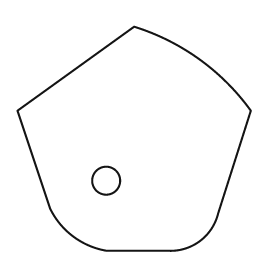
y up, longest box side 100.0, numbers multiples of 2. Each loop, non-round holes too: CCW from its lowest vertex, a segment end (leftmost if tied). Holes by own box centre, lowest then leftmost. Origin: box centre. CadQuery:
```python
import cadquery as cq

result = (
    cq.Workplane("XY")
    .moveTo(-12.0, -48.0)
    .lineTo(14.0, -48.0)
    .threePointArc((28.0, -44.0), (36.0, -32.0))
    .lineTo(50.0, 12.0)
    .threePointArc((28.0, 34.0), (0.0, 48.0))
    .lineTo(-50.0, 12.0)
    .lineTo(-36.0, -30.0)
    .threePointArc((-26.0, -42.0), (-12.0, -48.0))
    .close()
    .moveTo(-12.0, -18.0)
    .circle(6.0)
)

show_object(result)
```